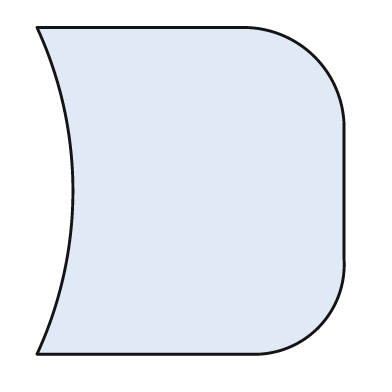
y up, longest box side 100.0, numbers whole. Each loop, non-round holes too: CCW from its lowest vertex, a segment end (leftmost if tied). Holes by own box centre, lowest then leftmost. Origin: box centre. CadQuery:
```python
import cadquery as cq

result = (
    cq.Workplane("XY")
    .moveTo(-47.0, -50.0)
    .lineTo(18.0, -50.0)
    .threePointArc((39.0, -42.0), (47.0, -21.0))
    .lineTo(47.0, 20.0)
    .threePointArc((38.0, 41.0), (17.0, 50.0))
    .lineTo(-47.0, 50.0)
    .threePointArc((-36.0, 0.0), (-47.0, -50.0))
    .close()
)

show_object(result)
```